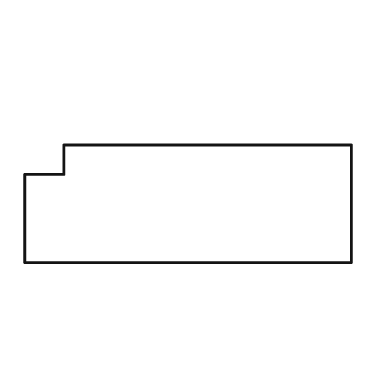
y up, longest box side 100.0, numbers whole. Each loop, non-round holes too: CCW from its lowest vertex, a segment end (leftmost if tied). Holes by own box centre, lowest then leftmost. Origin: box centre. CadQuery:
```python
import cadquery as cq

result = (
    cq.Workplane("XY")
    .moveTo(-50.0, -18.0)
    .lineTo(50.0, -18.0)
    .lineTo(50.0, 18.0)
    .lineTo(-38.0, 18.0)
    .lineTo(-38.0, 9.0)
    .lineTo(-50.0, 9.0)
    .close()
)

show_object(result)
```